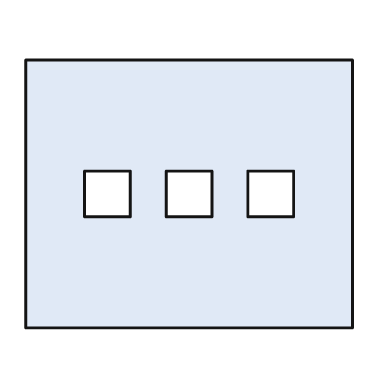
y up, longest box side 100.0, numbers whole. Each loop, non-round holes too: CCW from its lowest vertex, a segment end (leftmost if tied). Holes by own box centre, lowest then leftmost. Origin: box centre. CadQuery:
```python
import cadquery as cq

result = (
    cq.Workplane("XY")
    .moveTo(-50.0, -41.0)
    .lineTo(50.0, -41.0)
    .lineTo(50.0, 41.0)
    .lineTo(-50.0, 41.0)
    .close()
    .moveTo(-32.0, -7.0)
    .lineTo(-18.0, -7.0)
    .lineTo(-18.0, 7.0)
    .lineTo(-32.0, 7.0)
    .close()
    .moveTo(-7.0, -7.0)
    .lineTo(7.0, -7.0)
    .lineTo(7.0, 7.0)
    .lineTo(-7.0, 7.0)
    .close()
    .moveTo(18.0, -7.0)
    .lineTo(32.0, -7.0)
    .lineTo(32.0, 7.0)
    .lineTo(18.0, 7.0)
    .close()
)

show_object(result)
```